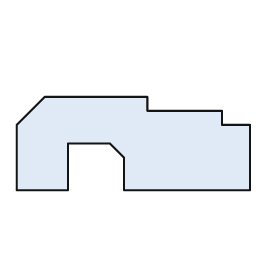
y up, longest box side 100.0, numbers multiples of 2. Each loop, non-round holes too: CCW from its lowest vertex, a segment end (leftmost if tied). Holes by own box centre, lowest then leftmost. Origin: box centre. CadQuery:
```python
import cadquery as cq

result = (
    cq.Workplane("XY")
    .moveTo(-50.0, -20.0)
    .lineTo(-28.0, -20.0)
    .lineTo(-28.0, 0.0)
    .lineTo(-10.0, 0.0)
    .lineTo(-4.0, -6.0)
    .lineTo(-4.0, -20.0)
    .lineTo(50.0, -20.0)
    .lineTo(50.0, 8.0)
    .lineTo(38.0, 8.0)
    .lineTo(38.0, 14.0)
    .lineTo(6.0, 14.0)
    .lineTo(6.0, 20.0)
    .lineTo(-38.0, 20.0)
    .lineTo(-50.0, 8.0)
    .close()
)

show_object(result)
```